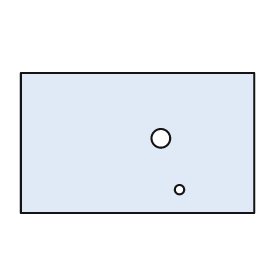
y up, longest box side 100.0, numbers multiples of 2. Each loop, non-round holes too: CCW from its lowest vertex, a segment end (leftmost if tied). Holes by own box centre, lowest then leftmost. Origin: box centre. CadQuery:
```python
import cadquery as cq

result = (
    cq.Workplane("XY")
    .moveTo(-50.0, -30.0)
    .lineTo(50.0, -30.0)
    .lineTo(50.0, 30.0)
    .lineTo(-50.0, 30.0)
    .close()
    .moveTo(18.0, -20.0)
    .circle(2.0)
    .moveTo(10.0, 2.0)
    .circle(4.0)
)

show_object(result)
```